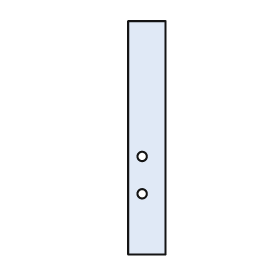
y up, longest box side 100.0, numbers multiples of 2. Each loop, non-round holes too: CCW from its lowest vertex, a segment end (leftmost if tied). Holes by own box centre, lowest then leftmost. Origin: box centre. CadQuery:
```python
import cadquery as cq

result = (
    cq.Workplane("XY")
    .moveTo(-8.0, -50.0)
    .lineTo(8.0, -50.0)
    .lineTo(8.0, 50.0)
    .lineTo(-8.0, 50.0)
    .close()
    .moveTo(-2.0, -24.0)
    .circle(2.0)
    .moveTo(-2.0, -8.0)
    .circle(2.0)
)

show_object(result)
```